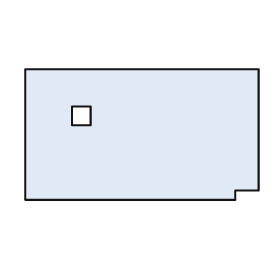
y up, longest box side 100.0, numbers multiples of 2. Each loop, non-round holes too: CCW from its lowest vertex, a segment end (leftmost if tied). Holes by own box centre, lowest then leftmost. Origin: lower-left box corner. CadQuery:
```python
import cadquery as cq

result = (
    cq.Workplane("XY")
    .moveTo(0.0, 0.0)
    .lineTo(90.0, 0.0)
    .lineTo(90.0, 4.0)
    .lineTo(100.0, 4.0)
    .lineTo(100.0, 56.0)
    .lineTo(0.0, 56.0)
    .close()
    .moveTo(20.0, 32.0)
    .lineTo(28.0, 32.0)
    .lineTo(28.0, 40.0)
    .lineTo(20.0, 40.0)
    .close()
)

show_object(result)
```